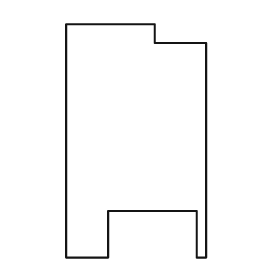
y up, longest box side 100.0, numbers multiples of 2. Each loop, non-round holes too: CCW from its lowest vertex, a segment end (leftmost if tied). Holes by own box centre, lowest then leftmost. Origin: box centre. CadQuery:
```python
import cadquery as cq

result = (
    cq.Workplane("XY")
    .moveTo(-30.0, -50.0)
    .lineTo(-12.0, -50.0)
    .lineTo(-12.0, -30.0)
    .lineTo(26.0, -30.0)
    .lineTo(26.0, -50.0)
    .lineTo(30.0, -50.0)
    .lineTo(30.0, 42.0)
    .lineTo(8.0, 42.0)
    .lineTo(8.0, 50.0)
    .lineTo(-30.0, 50.0)
    .close()
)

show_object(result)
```